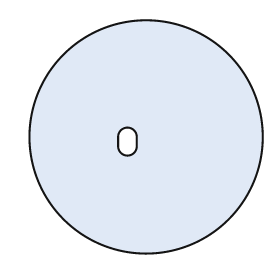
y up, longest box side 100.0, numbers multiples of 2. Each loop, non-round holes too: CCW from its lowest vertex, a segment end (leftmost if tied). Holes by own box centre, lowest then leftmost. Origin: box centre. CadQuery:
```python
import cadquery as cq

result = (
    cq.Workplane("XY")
    .moveTo(0.0, 0.0)
    .circle(50.0)
    .moveTo(-12.0, -4.0)
    .threePointArc((-8.0, -8.0), (-4.0, -4.0))
    .lineTo(-4.0, 0.0)
    .threePointArc((-8.0, 4.0), (-12.0, 0.0))
    .close()
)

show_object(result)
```